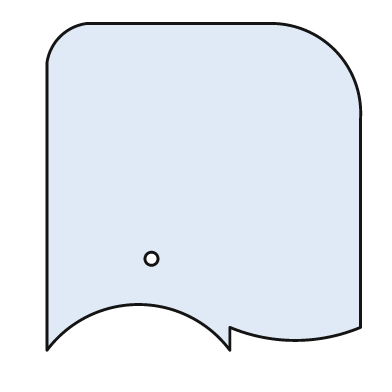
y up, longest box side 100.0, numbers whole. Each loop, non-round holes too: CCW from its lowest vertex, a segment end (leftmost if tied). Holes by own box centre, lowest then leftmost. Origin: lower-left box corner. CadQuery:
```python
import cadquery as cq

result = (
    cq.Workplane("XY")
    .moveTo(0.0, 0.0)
    .threePointArc((28.0, 14.0), (56.0, 0.0))
    .lineTo(56.0, 7.0)
    .threePointArc((76.0, 3.0), (96.0, 7.0))
    .lineTo(96.0, 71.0)
    .threePointArc((88.0, 92.0), (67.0, 100.0))
    .lineTo(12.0, 100.0)
    .threePointArc((4.0, 96.0), (0.0, 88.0))
    .close()
    .moveTo(32.0, 28.0)
    .circle(2.0)
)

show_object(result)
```